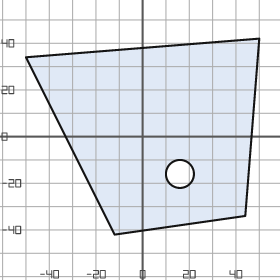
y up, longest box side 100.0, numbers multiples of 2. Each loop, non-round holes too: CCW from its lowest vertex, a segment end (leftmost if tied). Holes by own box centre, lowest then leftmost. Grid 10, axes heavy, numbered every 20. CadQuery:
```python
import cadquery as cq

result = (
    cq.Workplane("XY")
    .moveTo(-12.0, -42.0)
    .lineTo(44.0, -34.0)
    .lineTo(50.0, 42.0)
    .lineTo(-50.0, 34.0)
    .close()
    .moveTo(16.0, -16.0)
    .circle(6.0)
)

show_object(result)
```